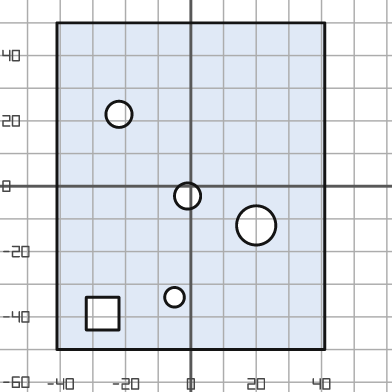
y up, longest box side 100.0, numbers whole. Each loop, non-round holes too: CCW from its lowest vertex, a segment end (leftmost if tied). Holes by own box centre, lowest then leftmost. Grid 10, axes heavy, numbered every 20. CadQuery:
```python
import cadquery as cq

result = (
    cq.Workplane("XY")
    .moveTo(-41.0, -50.0)
    .lineTo(41.0, -50.0)
    .lineTo(41.0, 50.0)
    .lineTo(-41.0, 50.0)
    .close()
    .moveTo(-32.0, -44.0)
    .lineTo(-22.0, -44.0)
    .lineTo(-22.0, -34.0)
    .lineTo(-32.0, -34.0)
    .close()
    .moveTo(-5.0, -34.0)
    .circle(3.0)
    .moveTo(20.0, -12.0)
    .circle(6.0)
    .moveTo(-1.0, -3.0)
    .circle(4.0)
    .moveTo(-22.0, 22.0)
    .circle(4.0)
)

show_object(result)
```